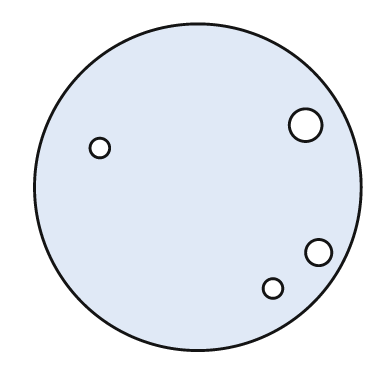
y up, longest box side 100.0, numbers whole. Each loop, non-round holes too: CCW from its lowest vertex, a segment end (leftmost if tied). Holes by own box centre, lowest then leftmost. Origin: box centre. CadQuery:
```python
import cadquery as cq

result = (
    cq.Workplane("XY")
    .moveTo(0.0, 0.0)
    .circle(50.0)
    .moveTo(23.0, -31.0)
    .circle(3.0)
    .moveTo(37.0, -20.0)
    .circle(4.0)
    .moveTo(-30.0, 12.0)
    .circle(3.0)
    .moveTo(33.0, 19.0)
    .circle(5.0)
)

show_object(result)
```